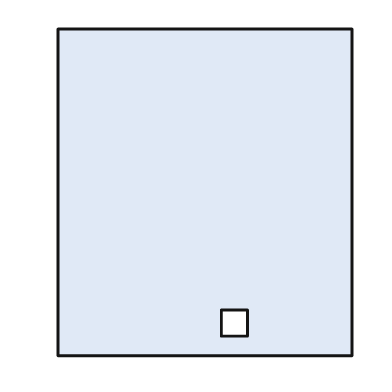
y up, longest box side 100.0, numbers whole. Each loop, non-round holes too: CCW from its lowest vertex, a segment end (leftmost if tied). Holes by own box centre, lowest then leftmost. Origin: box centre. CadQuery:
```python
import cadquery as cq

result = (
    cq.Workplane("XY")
    .moveTo(-45.0, -50.0)
    .lineTo(45.0, -50.0)
    .lineTo(45.0, 50.0)
    .lineTo(-45.0, 50.0)
    .close()
    .moveTo(5.0, -44.0)
    .lineTo(13.0, -44.0)
    .lineTo(13.0, -36.0)
    .lineTo(5.0, -36.0)
    .close()
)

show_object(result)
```